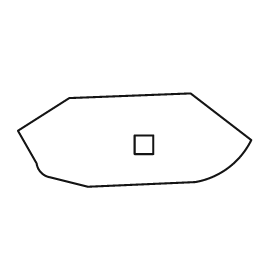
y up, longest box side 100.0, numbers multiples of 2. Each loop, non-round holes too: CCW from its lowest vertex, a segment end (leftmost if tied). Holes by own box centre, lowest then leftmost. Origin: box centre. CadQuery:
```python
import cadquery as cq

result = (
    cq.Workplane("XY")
    .moveTo(-20.0, -20.0)
    .lineTo(26.0, -18.0)
    .threePointArc((40.0, -12.0), (50.0, 0.0))
    .lineTo(24.0, 20.0)
    .lineTo(-28.0, 18.0)
    .lineTo(-50.0, 4.0)
    .lineTo(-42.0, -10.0)
    .threePointArc((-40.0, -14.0), (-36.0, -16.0))
    .close()
    .moveTo(0.0, -6.0)
    .lineTo(8.0, -6.0)
    .lineTo(8.0, 2.0)
    .lineTo(0.0, 2.0)
    .close()
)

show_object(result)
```